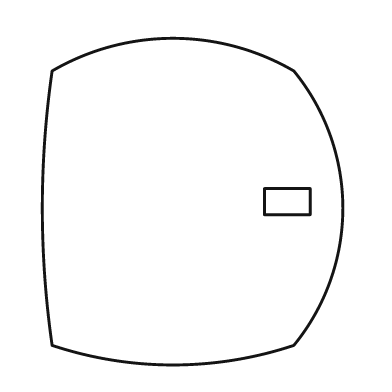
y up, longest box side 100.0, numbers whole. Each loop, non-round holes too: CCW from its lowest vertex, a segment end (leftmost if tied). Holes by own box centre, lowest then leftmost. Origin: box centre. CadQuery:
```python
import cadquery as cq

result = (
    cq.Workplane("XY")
    .moveTo(-43.0, -44.0)
    .threePointArc((-6.0, -50.0), (31.0, -44.0))
    .threePointArc((46.0, -2.0), (31.0, 40.0))
    .threePointArc((-6.0, 50.0), (-43.0, 40.0))
    .threePointArc((-46.0, -2.0), (-43.0, -44.0))
    .close()
    .moveTo(22.0, -4.0)
    .lineTo(36.0, -4.0)
    .lineTo(36.0, 4.0)
    .lineTo(22.0, 4.0)
    .close()
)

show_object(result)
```